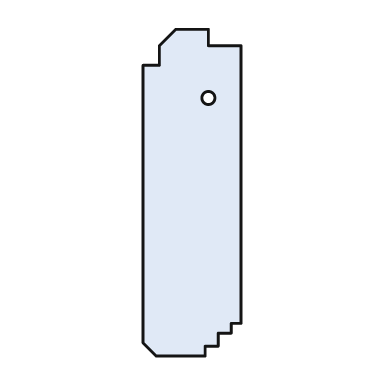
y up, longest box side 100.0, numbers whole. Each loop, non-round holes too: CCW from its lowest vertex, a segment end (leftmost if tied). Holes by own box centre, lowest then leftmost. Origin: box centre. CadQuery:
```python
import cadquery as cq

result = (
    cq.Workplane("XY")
    .moveTo(-11.0, -50.0)
    .lineTo(4.0, -50.0)
    .lineTo(4.0, -47.0)
    .lineTo(8.0, -47.0)
    .lineTo(8.0, -43.0)
    .lineTo(12.0, -43.0)
    .lineTo(12.0, -40.0)
    .lineTo(15.0, -40.0)
    .lineTo(15.0, 45.0)
    .lineTo(5.0, 45.0)
    .lineTo(5.0, 50.0)
    .lineTo(-5.0, 50.0)
    .lineTo(-10.0, 45.0)
    .lineTo(-10.0, 39.0)
    .lineTo(-15.0, 39.0)
    .lineTo(-15.0, -46.0)
    .close()
    .moveTo(5.0, 29.0)
    .circle(2.0)
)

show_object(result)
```